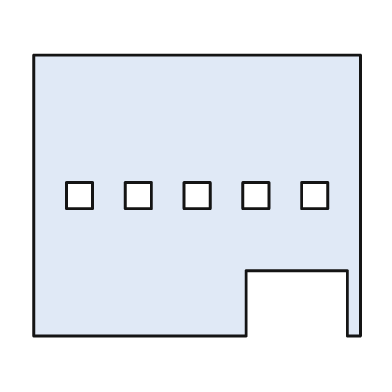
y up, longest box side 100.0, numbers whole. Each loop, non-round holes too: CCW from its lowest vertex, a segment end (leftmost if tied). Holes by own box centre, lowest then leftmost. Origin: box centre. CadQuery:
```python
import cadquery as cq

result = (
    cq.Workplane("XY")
    .moveTo(-50.0, -43.0)
    .lineTo(15.0, -43.0)
    .lineTo(15.0, -23.0)
    .lineTo(46.0, -23.0)
    .lineTo(46.0, -43.0)
    .lineTo(50.0, -43.0)
    .lineTo(50.0, 43.0)
    .lineTo(-50.0, 43.0)
    .close()
    .moveTo(-40.0, -4.0)
    .lineTo(-32.0, -4.0)
    .lineTo(-32.0, 4.0)
    .lineTo(-40.0, 4.0)
    .close()
    .moveTo(-22.0, -4.0)
    .lineTo(-14.0, -4.0)
    .lineTo(-14.0, 4.0)
    .lineTo(-22.0, 4.0)
    .close()
    .moveTo(-4.0, -4.0)
    .lineTo(4.0, -4.0)
    .lineTo(4.0, 4.0)
    .lineTo(-4.0, 4.0)
    .close()
    .moveTo(14.0, -4.0)
    .lineTo(22.0, -4.0)
    .lineTo(22.0, 4.0)
    .lineTo(14.0, 4.0)
    .close()
    .moveTo(32.0, -4.0)
    .lineTo(40.0, -4.0)
    .lineTo(40.0, 4.0)
    .lineTo(32.0, 4.0)
    .close()
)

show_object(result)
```